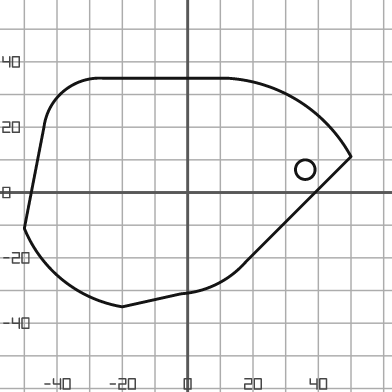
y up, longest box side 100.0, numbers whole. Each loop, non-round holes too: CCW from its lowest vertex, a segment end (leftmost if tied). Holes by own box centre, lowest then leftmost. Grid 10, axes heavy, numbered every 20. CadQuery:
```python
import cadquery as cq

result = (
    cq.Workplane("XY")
    .moveTo(-20.0, -35.0)
    .lineTo(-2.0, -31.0)
    .threePointArc((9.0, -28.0), (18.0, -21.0))
    .lineTo(50.0, 11.0)
    .threePointArc((34.0, 28.0), (12.0, 35.0))
    .lineTo(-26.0, 35.0)
    .threePointArc((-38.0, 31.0), (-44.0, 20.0))
    .lineTo(-50.0, -11.0)
    .threePointArc((-38.0, -27.0), (-20.0, -35.0))
    .close()
    .moveTo(36.0, 7.0)
    .circle(3.0)
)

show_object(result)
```